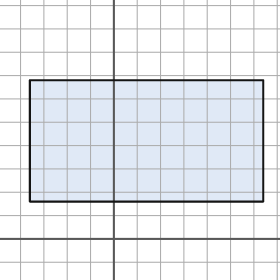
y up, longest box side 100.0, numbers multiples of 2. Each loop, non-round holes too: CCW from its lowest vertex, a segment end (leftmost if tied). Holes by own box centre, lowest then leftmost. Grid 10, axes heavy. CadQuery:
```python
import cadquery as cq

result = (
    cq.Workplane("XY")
    .moveTo(-36.0, 16.0)
    .lineTo(64.0, 16.0)
    .lineTo(64.0, 68.0)
    .lineTo(-36.0, 68.0)
    .close()
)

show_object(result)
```